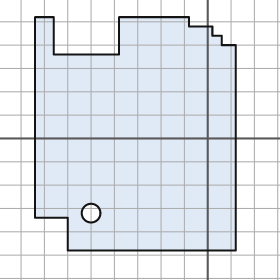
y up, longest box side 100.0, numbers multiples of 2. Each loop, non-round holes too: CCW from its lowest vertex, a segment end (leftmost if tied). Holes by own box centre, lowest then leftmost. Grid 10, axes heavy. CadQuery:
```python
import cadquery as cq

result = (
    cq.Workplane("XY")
    .moveTo(-60.0, -48.0)
    .lineTo(12.0, -48.0)
    .lineTo(12.0, 40.0)
    .lineTo(6.0, 40.0)
    .lineTo(6.0, 44.0)
    .lineTo(2.0, 44.0)
    .lineTo(2.0, 48.0)
    .lineTo(-8.0, 48.0)
    .lineTo(-8.0, 52.0)
    .lineTo(-38.0, 52.0)
    .lineTo(-38.0, 36.0)
    .lineTo(-66.0, 36.0)
    .lineTo(-66.0, 52.0)
    .lineTo(-74.0, 52.0)
    .lineTo(-74.0, -34.0)
    .lineTo(-60.0, -34.0)
    .close()
    .moveTo(-50.0, -32.0)
    .circle(4.0)
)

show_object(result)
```